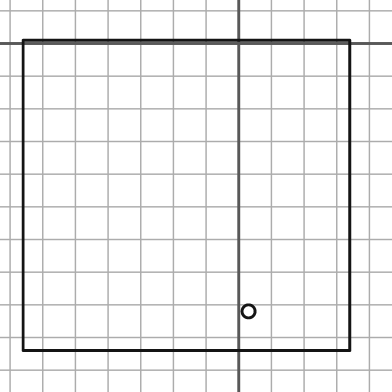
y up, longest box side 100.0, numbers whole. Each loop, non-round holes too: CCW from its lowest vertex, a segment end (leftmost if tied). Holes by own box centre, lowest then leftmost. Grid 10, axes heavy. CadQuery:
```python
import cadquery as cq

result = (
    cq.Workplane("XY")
    .moveTo(-66.0, -94.0)
    .lineTo(34.0, -94.0)
    .lineTo(34.0, 1.0)
    .lineTo(-66.0, 1.0)
    .close()
    .moveTo(3.0, -82.0)
    .circle(2.0)
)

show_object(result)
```